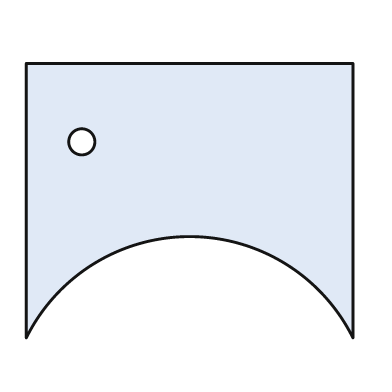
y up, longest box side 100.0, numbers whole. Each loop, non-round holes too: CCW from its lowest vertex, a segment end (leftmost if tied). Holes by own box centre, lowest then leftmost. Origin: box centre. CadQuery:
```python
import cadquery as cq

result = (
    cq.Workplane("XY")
    .moveTo(-50.0, -42.0)
    .threePointArc((0.0, -11.0), (50.0, -42.0))
    .lineTo(50.0, 42.0)
    .lineTo(-50.0, 42.0)
    .close()
    .moveTo(-33.0, 18.0)
    .circle(4.0)
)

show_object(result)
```